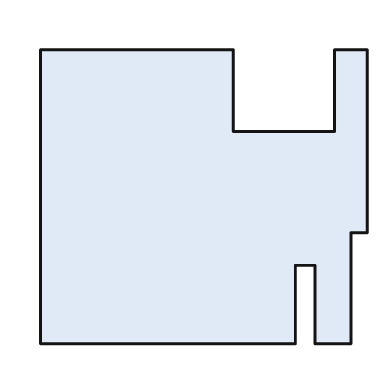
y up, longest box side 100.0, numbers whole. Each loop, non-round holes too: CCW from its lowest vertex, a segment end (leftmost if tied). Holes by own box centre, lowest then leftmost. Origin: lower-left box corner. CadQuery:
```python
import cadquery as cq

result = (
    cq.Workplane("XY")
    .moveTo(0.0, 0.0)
    .lineTo(78.0, 0.0)
    .lineTo(78.0, 24.0)
    .lineTo(84.0, 24.0)
    .lineTo(84.0, 0.0)
    .lineTo(95.0, 0.0)
    .lineTo(95.0, 34.0)
    .lineTo(100.0, 34.0)
    .lineTo(100.0, 90.0)
    .lineTo(90.0, 90.0)
    .lineTo(90.0, 65.0)
    .lineTo(59.0, 65.0)
    .lineTo(59.0, 90.0)
    .lineTo(0.0, 90.0)
    .close()
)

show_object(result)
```